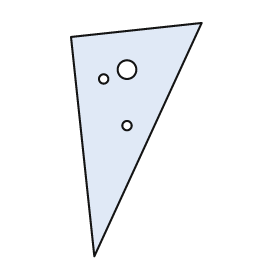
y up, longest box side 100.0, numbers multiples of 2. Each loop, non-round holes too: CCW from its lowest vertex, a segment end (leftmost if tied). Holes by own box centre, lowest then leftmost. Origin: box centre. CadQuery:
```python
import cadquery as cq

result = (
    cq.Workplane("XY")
    .moveTo(-18.0, -50.0)
    .lineTo(28.0, 50.0)
    .lineTo(-28.0, 44.0)
    .close()
    .moveTo(-4.0, 6.0)
    .circle(2.0)
    .moveTo(-14.0, 26.0)
    .circle(2.0)
    .moveTo(-4.0, 30.0)
    .circle(4.0)
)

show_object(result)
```